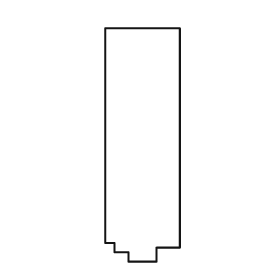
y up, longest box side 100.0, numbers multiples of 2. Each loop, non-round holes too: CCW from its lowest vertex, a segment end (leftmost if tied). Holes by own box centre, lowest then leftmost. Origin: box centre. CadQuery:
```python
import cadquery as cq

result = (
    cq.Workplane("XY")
    .moveTo(-6.0, -50.0)
    .lineTo(6.0, -50.0)
    .lineTo(6.0, -44.0)
    .lineTo(16.0, -44.0)
    .lineTo(16.0, 50.0)
    .lineTo(-16.0, 50.0)
    .lineTo(-16.0, -42.0)
    .lineTo(-12.0, -42.0)
    .lineTo(-12.0, -46.0)
    .lineTo(-6.0, -46.0)
    .close()
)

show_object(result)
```